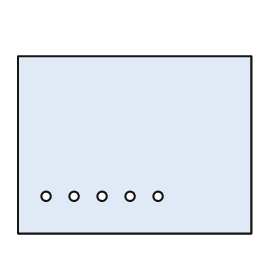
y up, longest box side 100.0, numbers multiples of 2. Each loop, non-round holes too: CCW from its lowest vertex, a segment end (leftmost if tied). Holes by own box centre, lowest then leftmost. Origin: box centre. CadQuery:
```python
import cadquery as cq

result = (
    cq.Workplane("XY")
    .moveTo(-50.0, -38.0)
    .lineTo(50.0, -38.0)
    .lineTo(50.0, 38.0)
    .lineTo(-50.0, 38.0)
    .close()
    .moveTo(-38.0, -22.0)
    .circle(2.0)
    .moveTo(-26.0, -22.0)
    .circle(2.0)
    .moveTo(-14.0, -22.0)
    .circle(2.0)
    .moveTo(-2.0, -22.0)
    .circle(2.0)
    .moveTo(10.0, -22.0)
    .circle(2.0)
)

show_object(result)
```